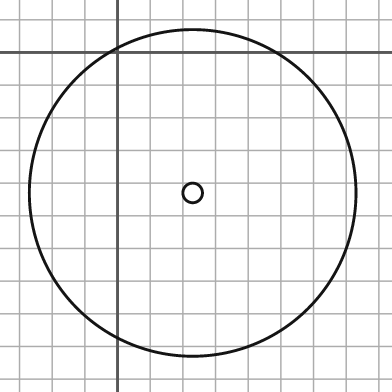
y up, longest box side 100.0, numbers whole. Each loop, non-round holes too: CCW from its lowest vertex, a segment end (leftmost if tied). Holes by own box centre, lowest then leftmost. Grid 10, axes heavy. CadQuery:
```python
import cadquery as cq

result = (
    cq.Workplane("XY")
    .moveTo(23.0, -43.0)
    .circle(50.0)
    .moveTo(23.0, -43.0)
    .circle(3.0)
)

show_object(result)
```